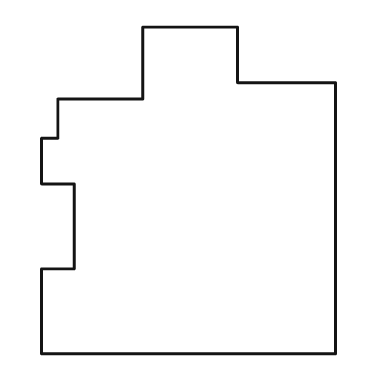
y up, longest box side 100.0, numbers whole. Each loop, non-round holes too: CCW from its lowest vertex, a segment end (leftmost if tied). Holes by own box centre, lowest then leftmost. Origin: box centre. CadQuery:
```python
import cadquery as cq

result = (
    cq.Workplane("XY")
    .moveTo(-45.0, -50.0)
    .lineTo(45.0, -50.0)
    .lineTo(45.0, 33.0)
    .lineTo(15.0, 33.0)
    .lineTo(15.0, 50.0)
    .lineTo(-14.0, 50.0)
    .lineTo(-14.0, 28.0)
    .lineTo(-40.0, 28.0)
    .lineTo(-40.0, 16.0)
    .lineTo(-45.0, 16.0)
    .lineTo(-45.0, 2.0)
    .lineTo(-35.0, 2.0)
    .lineTo(-35.0, -24.0)
    .lineTo(-45.0, -24.0)
    .close()
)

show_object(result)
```